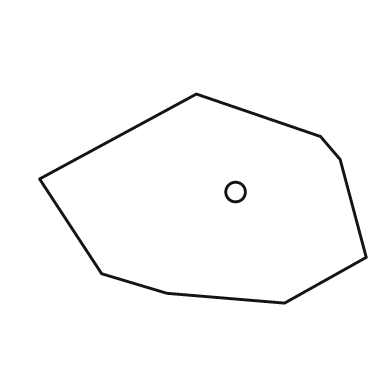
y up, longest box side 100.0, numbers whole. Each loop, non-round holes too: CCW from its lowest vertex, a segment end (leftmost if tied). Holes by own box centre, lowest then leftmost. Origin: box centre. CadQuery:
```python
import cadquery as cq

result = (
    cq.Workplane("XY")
    .moveTo(25.0, -32.0)
    .lineTo(50.0, -18.0)
    .lineTo(42.0, 12.0)
    .lineTo(36.0, 19.0)
    .lineTo(-2.0, 32.0)
    .lineTo(-50.0, 6.0)
    .lineTo(-31.0, -23.0)
    .lineTo(-11.0, -29.0)
    .close()
    .moveTo(10.0, 2.0)
    .circle(3.0)
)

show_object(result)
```